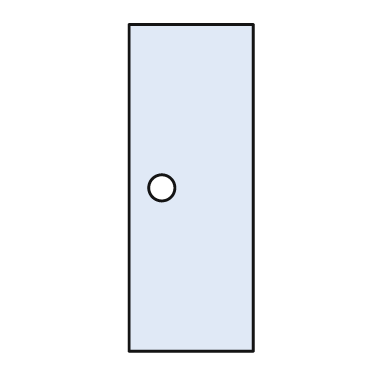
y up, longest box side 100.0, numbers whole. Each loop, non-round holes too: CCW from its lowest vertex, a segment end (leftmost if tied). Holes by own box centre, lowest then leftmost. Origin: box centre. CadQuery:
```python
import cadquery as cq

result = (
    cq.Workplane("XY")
    .moveTo(-19.0, -50.0)
    .lineTo(19.0, -50.0)
    .lineTo(19.0, 50.0)
    .lineTo(-19.0, 50.0)
    .close()
    .moveTo(-9.0, 0.0)
    .circle(4.0)
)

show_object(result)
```